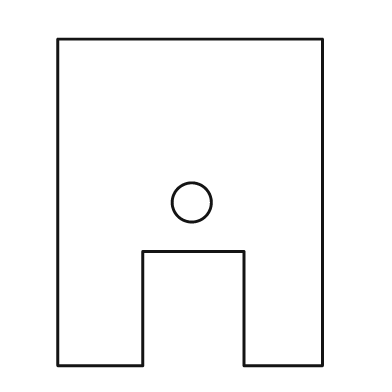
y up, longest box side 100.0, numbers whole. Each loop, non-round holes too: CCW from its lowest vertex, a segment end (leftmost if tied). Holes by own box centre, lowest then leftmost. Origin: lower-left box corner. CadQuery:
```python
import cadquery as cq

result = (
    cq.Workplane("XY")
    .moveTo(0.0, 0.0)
    .lineTo(26.0, 0.0)
    .lineTo(26.0, 35.0)
    .lineTo(57.0, 35.0)
    .lineTo(57.0, 0.0)
    .lineTo(81.0, 0.0)
    .lineTo(81.0, 100.0)
    .lineTo(0.0, 100.0)
    .close()
    .moveTo(41.0, 50.0)
    .circle(6.0)
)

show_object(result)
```